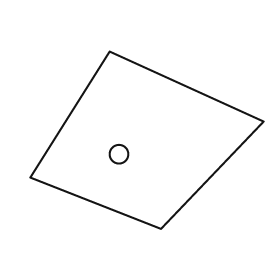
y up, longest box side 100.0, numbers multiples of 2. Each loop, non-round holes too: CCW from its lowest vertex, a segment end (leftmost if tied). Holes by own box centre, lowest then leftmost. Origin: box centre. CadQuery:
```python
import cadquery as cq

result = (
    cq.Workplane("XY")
    .moveTo(6.0, -38.0)
    .lineTo(50.0, 8.0)
    .lineTo(-16.0, 38.0)
    .lineTo(-50.0, -16.0)
    .close()
    .moveTo(-12.0, -6.0)
    .circle(4.0)
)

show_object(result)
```